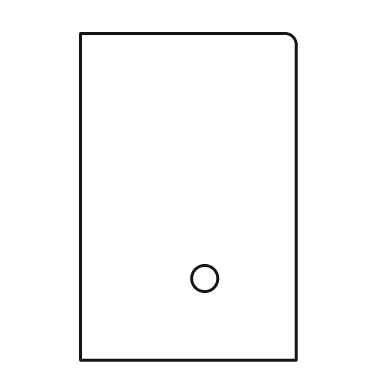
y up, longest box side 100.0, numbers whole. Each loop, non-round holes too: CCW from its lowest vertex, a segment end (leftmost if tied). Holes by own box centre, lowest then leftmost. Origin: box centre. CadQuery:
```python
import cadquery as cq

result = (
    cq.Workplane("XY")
    .moveTo(-33.0, -50.0)
    .lineTo(33.0, -50.0)
    .lineTo(33.0, 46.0)
    .threePointArc((32.0, 49.0), (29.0, 50.0))
    .lineTo(-33.0, 50.0)
    .close()
    .moveTo(5.0, -25.0)
    .circle(4.0)
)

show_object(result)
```